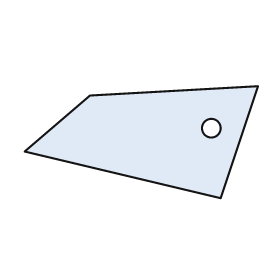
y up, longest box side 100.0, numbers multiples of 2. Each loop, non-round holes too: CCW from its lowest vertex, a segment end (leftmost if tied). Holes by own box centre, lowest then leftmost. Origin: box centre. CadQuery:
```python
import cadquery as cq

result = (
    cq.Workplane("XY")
    .moveTo(34.0, -24.0)
    .lineTo(50.0, 24.0)
    .lineTo(-22.0, 20.0)
    .lineTo(-50.0, -4.0)
    .close()
    .moveTo(30.0, 6.0)
    .circle(4.0)
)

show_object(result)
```